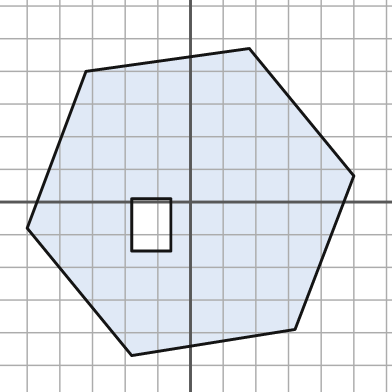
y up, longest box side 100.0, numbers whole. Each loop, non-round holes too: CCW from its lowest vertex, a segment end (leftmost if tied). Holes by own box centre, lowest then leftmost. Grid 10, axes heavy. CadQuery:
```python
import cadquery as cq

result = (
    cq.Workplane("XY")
    .moveTo(-18.0, -47.0)
    .lineTo(32.0, -39.0)
    .lineTo(50.0, 8.0)
    .lineTo(18.0, 47.0)
    .lineTo(-32.0, 40.0)
    .lineTo(-50.0, -8.0)
    .close()
    .moveTo(-18.0, -15.0)
    .lineTo(-6.0, -15.0)
    .lineTo(-6.0, 1.0)
    .lineTo(-18.0, 1.0)
    .close()
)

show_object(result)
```